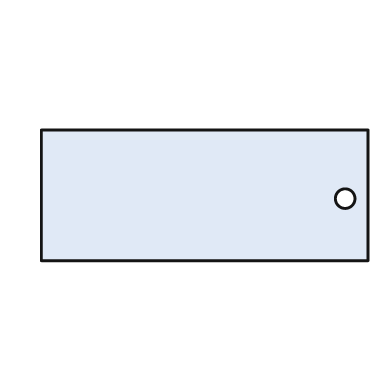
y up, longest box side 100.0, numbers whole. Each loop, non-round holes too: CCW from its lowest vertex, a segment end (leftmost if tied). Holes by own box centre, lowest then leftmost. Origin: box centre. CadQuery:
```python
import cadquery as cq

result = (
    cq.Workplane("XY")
    .moveTo(-50.0, -20.0)
    .lineTo(50.0, -20.0)
    .lineTo(50.0, 20.0)
    .lineTo(-50.0, 20.0)
    .close()
    .moveTo(43.0, -1.0)
    .circle(3.0)
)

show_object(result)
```